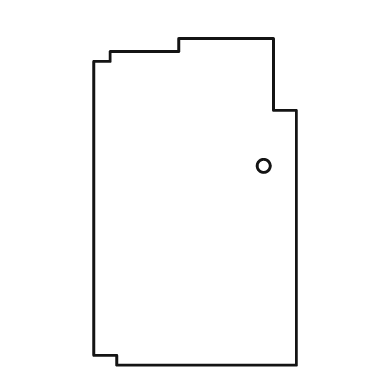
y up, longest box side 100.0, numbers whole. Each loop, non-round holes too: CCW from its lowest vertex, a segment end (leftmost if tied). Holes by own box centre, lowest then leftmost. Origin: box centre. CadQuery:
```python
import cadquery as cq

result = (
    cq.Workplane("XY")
    .moveTo(-24.0, -50.0)
    .lineTo(31.0, -50.0)
    .lineTo(31.0, 28.0)
    .lineTo(24.0, 28.0)
    .lineTo(24.0, 50.0)
    .lineTo(-5.0, 50.0)
    .lineTo(-5.0, 46.0)
    .lineTo(-26.0, 46.0)
    .lineTo(-26.0, 43.0)
    .lineTo(-31.0, 43.0)
    .lineTo(-31.0, -47.0)
    .lineTo(-24.0, -47.0)
    .close()
    .moveTo(21.0, 11.0)
    .circle(2.0)
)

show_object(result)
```